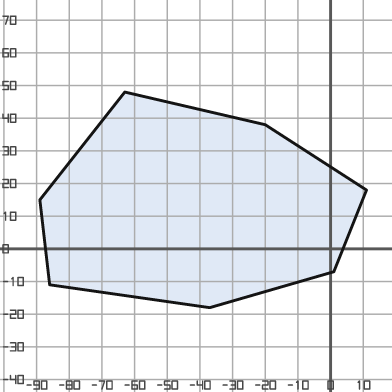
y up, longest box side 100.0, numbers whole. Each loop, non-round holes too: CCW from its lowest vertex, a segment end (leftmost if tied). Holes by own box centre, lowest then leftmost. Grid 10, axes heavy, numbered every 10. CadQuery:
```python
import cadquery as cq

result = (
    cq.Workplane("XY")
    .moveTo(-37.0, -18.0)
    .lineTo(1.0, -7.0)
    .lineTo(11.0, 18.0)
    .lineTo(-20.0, 38.0)
    .lineTo(-63.0, 48.0)
    .lineTo(-89.0, 15.0)
    .lineTo(-86.0, -11.0)
    .close()
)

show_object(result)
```